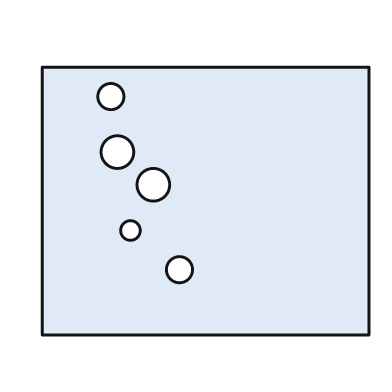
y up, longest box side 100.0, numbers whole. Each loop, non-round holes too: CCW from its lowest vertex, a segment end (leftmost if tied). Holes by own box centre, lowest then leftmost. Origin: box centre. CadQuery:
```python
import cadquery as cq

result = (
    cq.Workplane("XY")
    .moveTo(-50.0, -41.0)
    .lineTo(50.0, -41.0)
    .lineTo(50.0, 41.0)
    .lineTo(-50.0, 41.0)
    .close()
    .moveTo(-8.0, -21.0)
    .circle(4.0)
    .moveTo(-23.0, -9.0)
    .circle(3.0)
    .moveTo(-16.0, 5.0)
    .circle(5.0)
    .moveTo(-27.0, 15.0)
    .circle(5.0)
    .moveTo(-29.0, 32.0)
    .circle(4.0)
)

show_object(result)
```